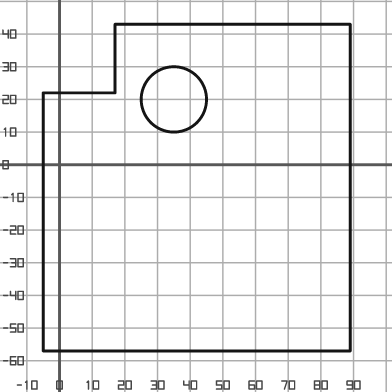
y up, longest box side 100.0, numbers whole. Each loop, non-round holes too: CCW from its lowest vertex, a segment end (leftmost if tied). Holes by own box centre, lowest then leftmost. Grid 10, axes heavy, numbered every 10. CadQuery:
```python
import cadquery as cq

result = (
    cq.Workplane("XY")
    .moveTo(-5.0, -57.0)
    .lineTo(89.0, -57.0)
    .lineTo(89.0, 43.0)
    .lineTo(17.0, 43.0)
    .lineTo(17.0, 22.0)
    .lineTo(-5.0, 22.0)
    .close()
    .moveTo(35.0, 20.0)
    .circle(10.0)
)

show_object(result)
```